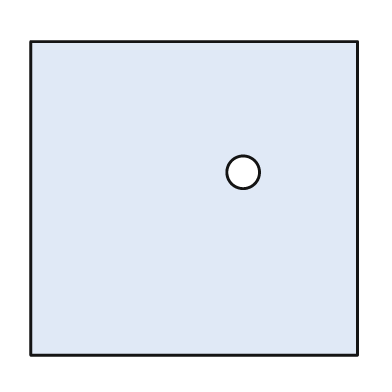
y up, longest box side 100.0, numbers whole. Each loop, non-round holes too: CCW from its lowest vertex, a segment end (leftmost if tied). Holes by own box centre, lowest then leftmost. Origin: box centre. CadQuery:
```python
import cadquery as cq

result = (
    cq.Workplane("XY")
    .moveTo(-50.0, -48.0)
    .lineTo(50.0, -48.0)
    .lineTo(50.0, 48.0)
    .lineTo(-50.0, 48.0)
    .close()
    .moveTo(15.0, 8.0)
    .circle(5.0)
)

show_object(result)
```